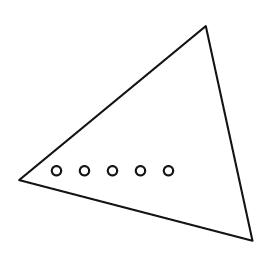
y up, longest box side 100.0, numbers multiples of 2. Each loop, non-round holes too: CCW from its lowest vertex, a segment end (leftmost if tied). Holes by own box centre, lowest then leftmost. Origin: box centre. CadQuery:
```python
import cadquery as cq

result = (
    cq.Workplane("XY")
    .moveTo(50.0, -46.0)
    .lineTo(30.0, 46.0)
    .lineTo(-50.0, -20.0)
    .close()
    .moveTo(-34.0, -16.0)
    .circle(2.0)
    .moveTo(-22.0, -16.0)
    .circle(2.0)
    .moveTo(-10.0, -16.0)
    .circle(2.0)
    .moveTo(2.0, -16.0)
    .circle(2.0)
    .moveTo(14.0, -16.0)
    .circle(2.0)
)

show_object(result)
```